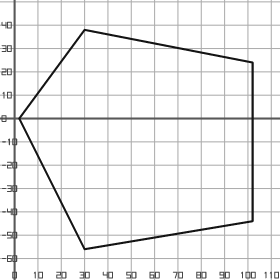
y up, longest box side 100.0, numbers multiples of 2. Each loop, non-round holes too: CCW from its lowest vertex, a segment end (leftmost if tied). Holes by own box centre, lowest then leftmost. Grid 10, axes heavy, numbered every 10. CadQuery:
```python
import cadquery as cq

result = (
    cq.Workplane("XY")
    .moveTo(30.0, -56.0)
    .lineTo(102.0, -44.0)
    .lineTo(102.0, 24.0)
    .lineTo(30.0, 38.0)
    .lineTo(2.0, 0.0)
    .close()
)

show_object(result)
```